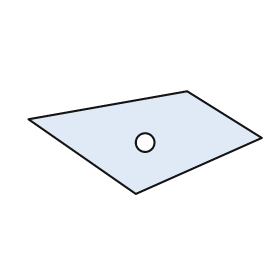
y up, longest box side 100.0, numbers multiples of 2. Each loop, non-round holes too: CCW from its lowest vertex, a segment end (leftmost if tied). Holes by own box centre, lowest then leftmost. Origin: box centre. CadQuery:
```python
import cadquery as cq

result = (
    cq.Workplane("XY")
    .moveTo(-4.0, -22.0)
    .lineTo(50.0, 2.0)
    .lineTo(18.0, 22.0)
    .lineTo(-50.0, 10.0)
    .close()
    .moveTo(0.0, 0.0)
    .circle(4.0)
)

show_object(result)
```